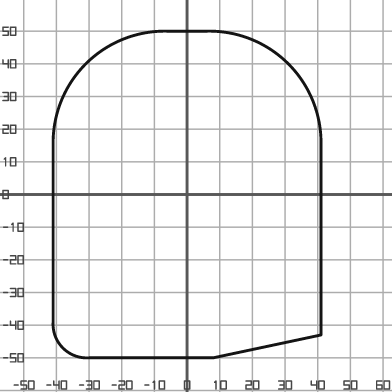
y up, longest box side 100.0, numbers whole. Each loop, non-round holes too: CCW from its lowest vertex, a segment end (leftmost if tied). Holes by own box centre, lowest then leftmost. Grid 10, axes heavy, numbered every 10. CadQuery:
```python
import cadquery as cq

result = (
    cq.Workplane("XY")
    .moveTo(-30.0, -50.0)
    .lineTo(8.0, -50.0)
    .lineTo(41.0, -43.0)
    .lineTo(41.0, 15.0)
    .threePointArc((31.0, 40.0), (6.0, 50.0))
    .lineTo(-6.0, 50.0)
    .threePointArc((-31.0, 40.0), (-41.0, 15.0))
    .lineTo(-41.0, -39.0)
    .threePointArc((-38.0, -47.0), (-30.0, -50.0))
    .close()
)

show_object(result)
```